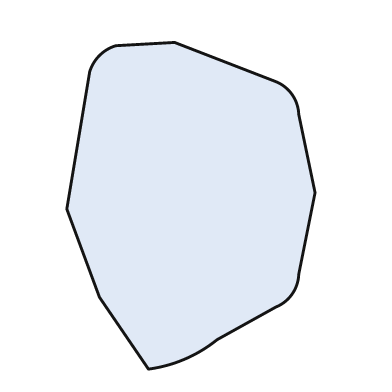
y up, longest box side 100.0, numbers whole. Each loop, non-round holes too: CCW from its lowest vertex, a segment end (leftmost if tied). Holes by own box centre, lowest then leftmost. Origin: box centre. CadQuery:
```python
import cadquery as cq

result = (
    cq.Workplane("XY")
    .moveTo(-13.0, -50.0)
    .threePointArc((-2.0, -47.0), (8.0, -41.0))
    .lineTo(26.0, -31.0)
    .threePointArc((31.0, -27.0), (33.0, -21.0))
    .lineTo(38.0, 4.0)
    .lineTo(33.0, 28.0)
    .threePointArc((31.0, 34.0), (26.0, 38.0))
    .lineTo(-5.0, 50.0)
    .lineTo(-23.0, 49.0)
    .threePointArc((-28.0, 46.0), (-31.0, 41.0))
    .lineTo(-38.0, -1.0)
    .lineTo(-28.0, -28.0)
    .close()
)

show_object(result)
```